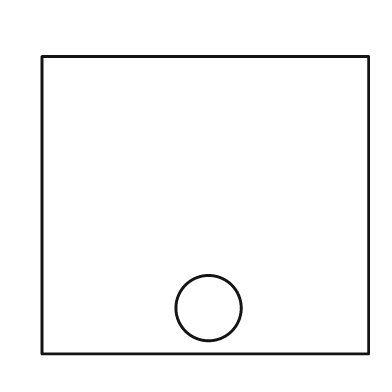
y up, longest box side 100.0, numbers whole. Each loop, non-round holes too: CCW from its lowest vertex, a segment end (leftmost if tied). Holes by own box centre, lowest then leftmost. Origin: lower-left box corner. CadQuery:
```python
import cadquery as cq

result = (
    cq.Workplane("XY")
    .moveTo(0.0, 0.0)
    .lineTo(100.0, 0.0)
    .lineTo(100.0, 91.0)
    .lineTo(0.0, 91.0)
    .close()
    .moveTo(51.0, 14.0)
    .circle(10.0)
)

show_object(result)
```